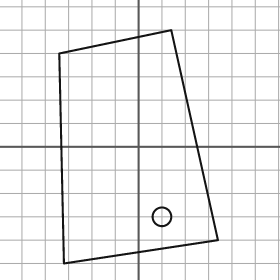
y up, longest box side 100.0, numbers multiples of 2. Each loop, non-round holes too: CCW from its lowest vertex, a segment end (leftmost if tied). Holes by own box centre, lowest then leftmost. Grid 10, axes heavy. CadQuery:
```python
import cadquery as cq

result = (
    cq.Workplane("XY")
    .moveTo(-32.0, -50.0)
    .lineTo(34.0, -40.0)
    .lineTo(14.0, 50.0)
    .lineTo(-34.0, 40.0)
    .close()
    .moveTo(10.0, -30.0)
    .circle(4.0)
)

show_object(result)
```